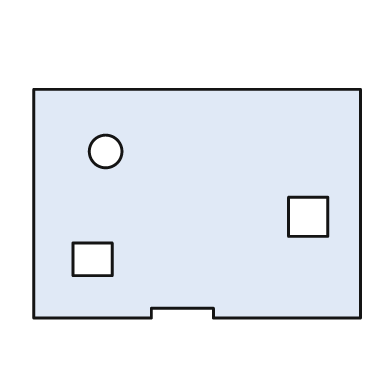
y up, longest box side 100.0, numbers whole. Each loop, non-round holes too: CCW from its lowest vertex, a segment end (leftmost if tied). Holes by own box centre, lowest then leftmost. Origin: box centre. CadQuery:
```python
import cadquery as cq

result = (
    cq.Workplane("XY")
    .moveTo(-50.0, -35.0)
    .lineTo(-14.0, -35.0)
    .lineTo(-14.0, -32.0)
    .lineTo(5.0, -32.0)
    .lineTo(5.0, -35.0)
    .lineTo(50.0, -35.0)
    .lineTo(50.0, 35.0)
    .lineTo(-50.0, 35.0)
    .close()
    .moveTo(-38.0, -22.0)
    .lineTo(-26.0, -22.0)
    .lineTo(-26.0, -12.0)
    .lineTo(-38.0, -12.0)
    .close()
    .moveTo(28.0, -10.0)
    .lineTo(40.0, -10.0)
    .lineTo(40.0, 2.0)
    .lineTo(28.0, 2.0)
    .close()
    .moveTo(-28.0, 16.0)
    .circle(5.0)
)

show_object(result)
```